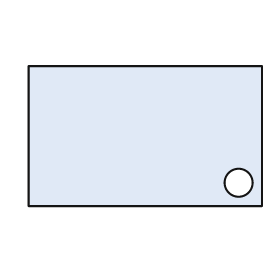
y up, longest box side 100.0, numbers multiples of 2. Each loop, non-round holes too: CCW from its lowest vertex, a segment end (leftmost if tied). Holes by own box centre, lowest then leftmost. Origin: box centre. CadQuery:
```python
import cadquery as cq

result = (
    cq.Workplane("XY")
    .moveTo(-50.0, -30.0)
    .lineTo(50.0, -30.0)
    .lineTo(50.0, 30.0)
    .lineTo(-50.0, 30.0)
    .close()
    .moveTo(40.0, -20.0)
    .circle(6.0)
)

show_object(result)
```